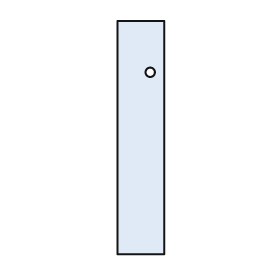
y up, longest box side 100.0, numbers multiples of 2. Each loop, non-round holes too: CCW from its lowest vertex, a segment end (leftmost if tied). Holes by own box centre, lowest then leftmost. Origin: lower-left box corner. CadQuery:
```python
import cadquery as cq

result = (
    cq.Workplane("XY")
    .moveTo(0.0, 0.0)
    .lineTo(20.0, 0.0)
    .lineTo(20.0, 100.0)
    .lineTo(0.0, 100.0)
    .close()
    .moveTo(14.0, 78.0)
    .circle(2.0)
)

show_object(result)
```